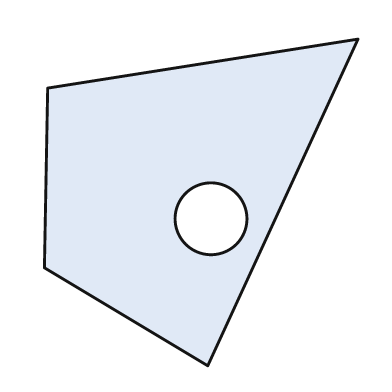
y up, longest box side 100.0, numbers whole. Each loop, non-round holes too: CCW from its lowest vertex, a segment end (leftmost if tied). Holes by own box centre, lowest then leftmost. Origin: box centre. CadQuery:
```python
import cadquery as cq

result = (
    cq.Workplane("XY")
    .moveTo(2.0, -50.0)
    .lineTo(48.0, 50.0)
    .lineTo(-47.0, 35.0)
    .lineTo(-48.0, -20.0)
    .close()
    .moveTo(3.0, -5.0)
    .circle(11.0)
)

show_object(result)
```